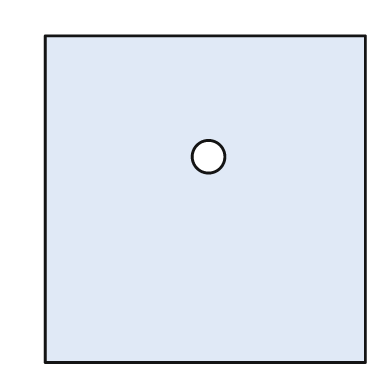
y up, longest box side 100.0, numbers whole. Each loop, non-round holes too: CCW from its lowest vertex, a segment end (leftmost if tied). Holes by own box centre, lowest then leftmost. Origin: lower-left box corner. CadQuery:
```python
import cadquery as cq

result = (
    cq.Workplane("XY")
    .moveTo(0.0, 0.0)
    .lineTo(98.0, 0.0)
    .lineTo(98.0, 100.0)
    .lineTo(0.0, 100.0)
    .close()
    .moveTo(50.0, 63.0)
    .circle(5.0)
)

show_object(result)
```